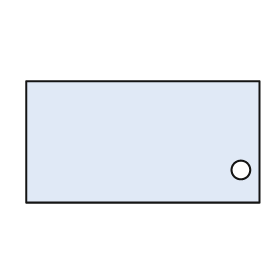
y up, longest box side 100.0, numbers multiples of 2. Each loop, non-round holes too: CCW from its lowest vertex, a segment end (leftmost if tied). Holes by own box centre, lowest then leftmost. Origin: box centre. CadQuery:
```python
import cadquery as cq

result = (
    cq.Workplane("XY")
    .moveTo(-50.0, -26.0)
    .lineTo(50.0, -26.0)
    .lineTo(50.0, 26.0)
    .lineTo(-50.0, 26.0)
    .close()
    .moveTo(42.0, -12.0)
    .circle(4.0)
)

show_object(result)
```